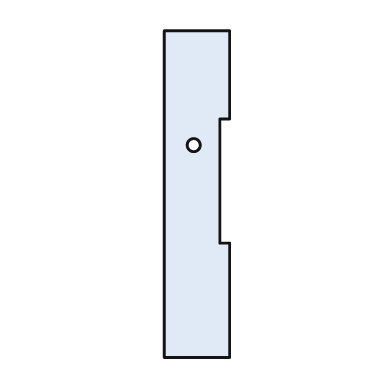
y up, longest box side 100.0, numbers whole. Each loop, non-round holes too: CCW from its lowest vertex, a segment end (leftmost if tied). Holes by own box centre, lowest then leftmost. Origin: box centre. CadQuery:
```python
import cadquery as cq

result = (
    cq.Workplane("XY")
    .moveTo(-10.0, -50.0)
    .lineTo(10.0, -50.0)
    .lineTo(10.0, -15.0)
    .lineTo(7.0, -15.0)
    .lineTo(7.0, 23.0)
    .lineTo(10.0, 23.0)
    .lineTo(10.0, 50.0)
    .lineTo(-10.0, 50.0)
    .close()
    .moveTo(-1.0, 15.0)
    .circle(2.0)
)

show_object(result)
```